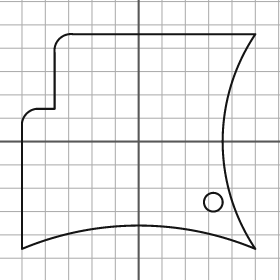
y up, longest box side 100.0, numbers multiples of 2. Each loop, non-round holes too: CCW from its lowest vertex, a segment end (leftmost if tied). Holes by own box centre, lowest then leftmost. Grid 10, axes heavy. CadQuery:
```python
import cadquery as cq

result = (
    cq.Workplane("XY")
    .moveTo(-50.0, -46.0)
    .threePointArc((0.0, -36.0), (50.0, -46.0))
    .threePointArc((36.0, 0.0), (50.0, 46.0))
    .lineTo(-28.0, 46.0)
    .threePointArc((-34.0, 44.0), (-36.0, 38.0))
    .lineTo(-36.0, 14.0)
    .lineTo(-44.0, 14.0)
    .threePointArc((-48.0, 12.0), (-50.0, 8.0))
    .close()
    .moveTo(32.0, -26.0)
    .circle(4.0)
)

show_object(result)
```